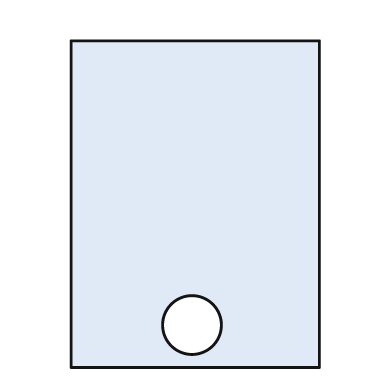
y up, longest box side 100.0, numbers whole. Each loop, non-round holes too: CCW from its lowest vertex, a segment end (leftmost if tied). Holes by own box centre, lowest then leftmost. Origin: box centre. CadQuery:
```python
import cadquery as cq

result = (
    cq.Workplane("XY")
    .moveTo(-38.0, -50.0)
    .lineTo(38.0, -50.0)
    .lineTo(38.0, 50.0)
    .lineTo(-38.0, 50.0)
    .close()
    .moveTo(-1.0, -37.0)
    .circle(9.0)
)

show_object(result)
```